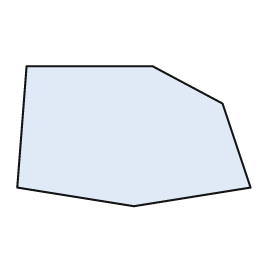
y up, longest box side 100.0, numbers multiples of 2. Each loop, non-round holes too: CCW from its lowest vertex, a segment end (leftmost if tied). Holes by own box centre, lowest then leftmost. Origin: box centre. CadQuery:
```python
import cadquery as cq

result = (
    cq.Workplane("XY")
    .moveTo(0.0, -30.0)
    .lineTo(50.0, -22.0)
    .lineTo(38.0, 14.0)
    .lineTo(8.0, 30.0)
    .lineTo(-46.0, 30.0)
    .lineTo(-50.0, -22.0)
    .close()
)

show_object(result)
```